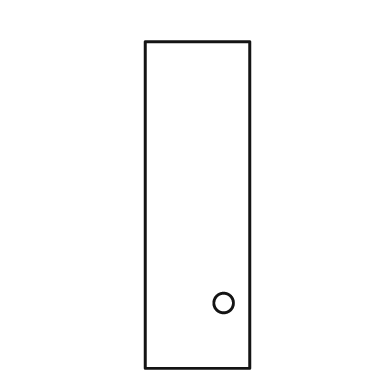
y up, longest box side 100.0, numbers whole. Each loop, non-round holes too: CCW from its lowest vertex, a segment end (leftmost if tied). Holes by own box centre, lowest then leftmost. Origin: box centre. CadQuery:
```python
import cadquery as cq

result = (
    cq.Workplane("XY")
    .moveTo(-16.0, -50.0)
    .lineTo(16.0, -50.0)
    .lineTo(16.0, 50.0)
    .lineTo(-16.0, 50.0)
    .close()
    .moveTo(8.0, -30.0)
    .circle(3.0)
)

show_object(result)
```